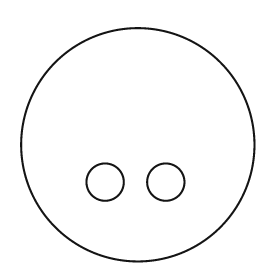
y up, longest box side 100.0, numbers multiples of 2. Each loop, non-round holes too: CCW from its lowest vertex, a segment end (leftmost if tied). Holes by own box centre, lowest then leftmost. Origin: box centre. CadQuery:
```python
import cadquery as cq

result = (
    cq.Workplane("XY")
    .moveTo(0.0, 0.0)
    .circle(50.0)
    .moveTo(-14.0, -16.0)
    .circle(8.0)
    .moveTo(12.0, -16.0)
    .circle(8.0)
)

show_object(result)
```